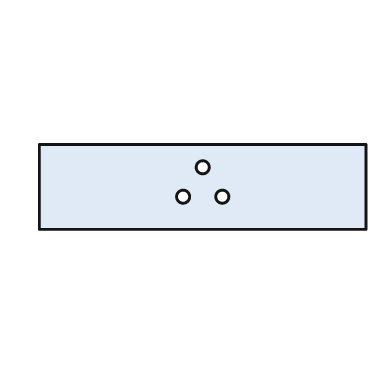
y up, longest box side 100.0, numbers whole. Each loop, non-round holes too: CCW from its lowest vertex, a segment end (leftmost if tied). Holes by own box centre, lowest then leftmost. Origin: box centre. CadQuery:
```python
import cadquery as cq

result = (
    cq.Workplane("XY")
    .moveTo(-50.0, -13.0)
    .lineTo(50.0, -13.0)
    .lineTo(50.0, 13.0)
    .lineTo(-50.0, 13.0)
    .close()
    .moveTo(-6.0, -3.0)
    .circle(2.0)
    .moveTo(6.0, -3.0)
    .circle(2.0)
    .moveTo(0.0, 6.0)
    .circle(2.0)
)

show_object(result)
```